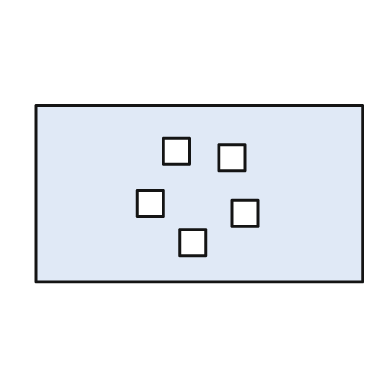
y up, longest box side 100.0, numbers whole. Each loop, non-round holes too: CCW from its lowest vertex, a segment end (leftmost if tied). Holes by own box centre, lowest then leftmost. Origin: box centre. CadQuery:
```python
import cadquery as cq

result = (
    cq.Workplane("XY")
    .moveTo(-50.0, -27.0)
    .lineTo(50.0, -27.0)
    .lineTo(50.0, 27.0)
    .lineTo(-50.0, 27.0)
    .close()
    .moveTo(-6.0, -19.0)
    .lineTo(2.0, -19.0)
    .lineTo(2.0, -11.0)
    .lineTo(-6.0, -11.0)
    .close()
    .moveTo(10.0, -10.0)
    .lineTo(18.0, -10.0)
    .lineTo(18.0, -2.0)
    .lineTo(10.0, -2.0)
    .close()
    .moveTo(-19.0, -7.0)
    .lineTo(-11.0, -7.0)
    .lineTo(-11.0, 1.0)
    .lineTo(-19.0, 1.0)
    .close()
    .moveTo(6.0, 7.0)
    .lineTo(14.0, 7.0)
    .lineTo(14.0, 15.0)
    .lineTo(6.0, 15.0)
    .close()
    .moveTo(-11.0, 9.0)
    .lineTo(-3.0, 9.0)
    .lineTo(-3.0, 17.0)
    .lineTo(-11.0, 17.0)
    .close()
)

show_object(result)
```